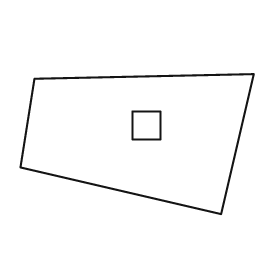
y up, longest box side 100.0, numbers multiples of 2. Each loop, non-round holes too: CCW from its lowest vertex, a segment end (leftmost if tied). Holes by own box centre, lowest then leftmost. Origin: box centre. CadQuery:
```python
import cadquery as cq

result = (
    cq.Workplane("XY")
    .moveTo(36.0, -30.0)
    .lineTo(50.0, 30.0)
    .lineTo(-44.0, 28.0)
    .lineTo(-50.0, -10.0)
    .close()
    .moveTo(-2.0, 2.0)
    .lineTo(10.0, 2.0)
    .lineTo(10.0, 14.0)
    .lineTo(-2.0, 14.0)
    .close()
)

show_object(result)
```